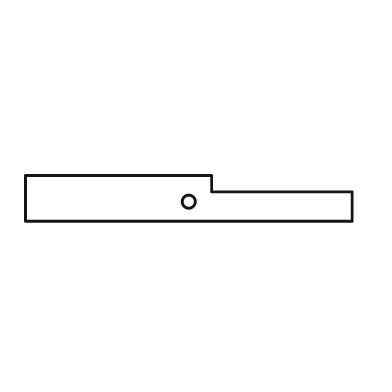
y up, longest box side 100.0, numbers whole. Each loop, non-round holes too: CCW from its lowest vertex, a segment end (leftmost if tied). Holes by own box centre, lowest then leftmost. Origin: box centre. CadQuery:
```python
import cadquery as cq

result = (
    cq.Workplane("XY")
    .moveTo(-50.0, -7.0)
    .lineTo(50.0, -7.0)
    .lineTo(50.0, 2.0)
    .lineTo(7.0, 2.0)
    .lineTo(7.0, 7.0)
    .lineTo(-50.0, 7.0)
    .close()
    .moveTo(0.0, -1.0)
    .circle(2.0)
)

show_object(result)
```